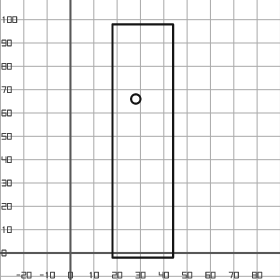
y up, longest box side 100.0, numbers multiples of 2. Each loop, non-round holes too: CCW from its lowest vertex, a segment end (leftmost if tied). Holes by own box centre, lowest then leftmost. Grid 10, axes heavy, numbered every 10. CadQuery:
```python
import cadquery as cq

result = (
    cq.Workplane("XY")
    .moveTo(18.0, -2.0)
    .lineTo(44.0, -2.0)
    .lineTo(44.0, 98.0)
    .lineTo(18.0, 98.0)
    .close()
    .moveTo(28.0, 66.0)
    .circle(2.0)
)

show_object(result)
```